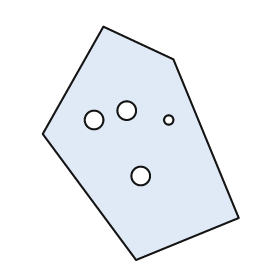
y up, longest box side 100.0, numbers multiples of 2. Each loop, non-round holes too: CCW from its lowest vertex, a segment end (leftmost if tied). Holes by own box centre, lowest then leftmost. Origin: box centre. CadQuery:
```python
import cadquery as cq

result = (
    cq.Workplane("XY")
    .moveTo(-2.0, -50.0)
    .lineTo(42.0, -32.0)
    .lineTo(14.0, 36.0)
    .lineTo(-16.0, 50.0)
    .lineTo(-42.0, 4.0)
    .close()
    .moveTo(0.0, -14.0)
    .circle(4.0)
    .moveTo(-20.0, 10.0)
    .circle(4.0)
    .moveTo(12.0, 10.0)
    .circle(2.0)
    .moveTo(-6.0, 14.0)
    .circle(4.0)
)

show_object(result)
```